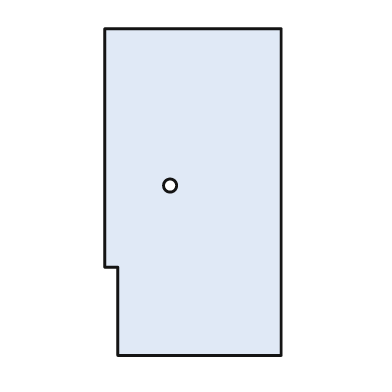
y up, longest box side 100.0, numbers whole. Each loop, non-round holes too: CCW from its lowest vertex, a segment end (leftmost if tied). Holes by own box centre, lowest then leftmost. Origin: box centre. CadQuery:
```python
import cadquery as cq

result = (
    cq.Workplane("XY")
    .moveTo(-23.0, -50.0)
    .lineTo(27.0, -50.0)
    .lineTo(27.0, 50.0)
    .lineTo(-27.0, 50.0)
    .lineTo(-27.0, -23.0)
    .lineTo(-23.0, -23.0)
    .close()
    .moveTo(-7.0, 2.0)
    .circle(2.0)
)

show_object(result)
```